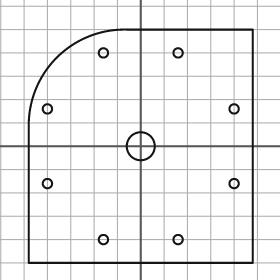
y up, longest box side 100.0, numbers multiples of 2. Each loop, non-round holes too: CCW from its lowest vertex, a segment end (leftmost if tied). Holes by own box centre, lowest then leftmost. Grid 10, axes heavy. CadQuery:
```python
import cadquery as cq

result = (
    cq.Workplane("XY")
    .moveTo(-48.0, -50.0)
    .lineTo(48.0, -50.0)
    .lineTo(48.0, 50.0)
    .lineTo(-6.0, 50.0)
    .threePointArc((-36.0, 38.0), (-48.0, 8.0))
    .close()
    .moveTo(-16.0, -40.0)
    .circle(2.0)
    .moveTo(16.0, -40.0)
    .circle(2.0)
    .moveTo(-40.0, -16.0)
    .circle(2.0)
    .moveTo(40.0, -16.0)
    .circle(2.0)
    .moveTo(0.0, 0.0)
    .circle(6.0)
    .moveTo(-40.0, 16.0)
    .circle(2.0)
    .moveTo(40.0, 16.0)
    .circle(2.0)
    .moveTo(-16.0, 40.0)
    .circle(2.0)
    .moveTo(16.0, 40.0)
    .circle(2.0)
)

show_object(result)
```